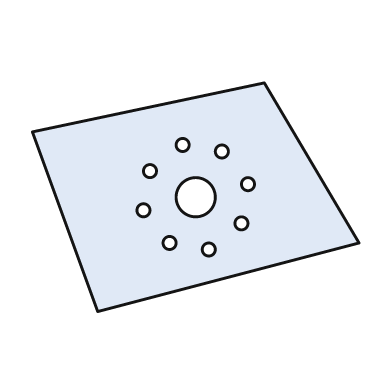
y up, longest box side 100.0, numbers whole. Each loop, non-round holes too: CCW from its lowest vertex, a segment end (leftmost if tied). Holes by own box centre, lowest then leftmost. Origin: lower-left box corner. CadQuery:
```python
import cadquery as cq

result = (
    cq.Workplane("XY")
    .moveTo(20.0, 0.0)
    .lineTo(100.0, 21.0)
    .lineTo(71.0, 70.0)
    .lineTo(0.0, 55.0)
    .close()
    .moveTo(54.0, 19.0)
    .circle(2.0)
    .moveTo(42.0, 21.0)
    .circle(2.0)
    .moveTo(64.0, 27.0)
    .circle(2.0)
    .moveTo(34.0, 31.0)
    .circle(2.0)
    .moveTo(50.0, 35.0)
    .circle(6.0)
    .moveTo(66.0, 39.0)
    .circle(2.0)
    .moveTo(36.0, 43.0)
    .circle(2.0)
    .moveTo(58.0, 49.0)
    .circle(2.0)
    .moveTo(46.0, 51.0)
    .circle(2.0)
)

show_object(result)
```